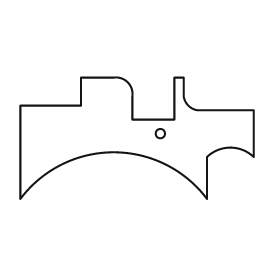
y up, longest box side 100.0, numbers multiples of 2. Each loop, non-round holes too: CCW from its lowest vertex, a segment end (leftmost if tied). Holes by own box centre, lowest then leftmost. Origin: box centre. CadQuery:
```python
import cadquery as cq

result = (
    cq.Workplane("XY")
    .moveTo(-50.0, -26.0)
    .threePointArc((-10.0, -6.0), (30.0, -26.0))
    .lineTo(30.0, -8.0)
    .threePointArc((40.0, -4.0), (50.0, -8.0))
    .lineTo(50.0, 12.0)
    .lineTo(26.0, 12.0)
    .threePointArc((22.0, 14.0), (20.0, 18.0))
    .lineTo(20.0, 26.0)
    .lineTo(16.0, 26.0)
    .lineTo(16.0, 8.0)
    .lineTo(-2.0, 8.0)
    .lineTo(-2.0, 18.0)
    .threePointArc((-4.0, 24.0), (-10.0, 26.0))
    .lineTo(-24.0, 26.0)
    .lineTo(-24.0, 14.0)
    .lineTo(-50.0, 14.0)
    .close()
    .moveTo(10.0, 2.0)
    .circle(2.0)
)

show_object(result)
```